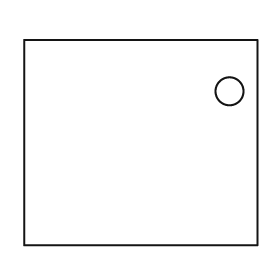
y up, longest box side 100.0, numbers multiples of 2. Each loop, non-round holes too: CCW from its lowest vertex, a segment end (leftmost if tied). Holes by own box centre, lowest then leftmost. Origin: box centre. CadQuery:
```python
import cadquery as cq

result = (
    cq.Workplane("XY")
    .moveTo(-50.0, -44.0)
    .lineTo(50.0, -44.0)
    .lineTo(50.0, 44.0)
    .lineTo(-50.0, 44.0)
    .close()
    .moveTo(38.0, 22.0)
    .circle(6.0)
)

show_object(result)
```